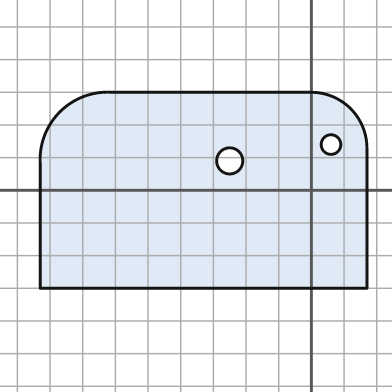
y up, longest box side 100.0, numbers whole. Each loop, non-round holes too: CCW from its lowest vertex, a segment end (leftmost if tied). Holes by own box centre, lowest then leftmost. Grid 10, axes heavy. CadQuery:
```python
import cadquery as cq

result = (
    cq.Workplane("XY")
    .moveTo(-83.0, -30.0)
    .lineTo(17.0, -30.0)
    .lineTo(17.0, 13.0)
    .threePointArc((12.0, 25.0), (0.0, 30.0))
    .lineTo(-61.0, 30.0)
    .threePointArc((-77.0, 24.0), (-83.0, 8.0))
    .close()
    .moveTo(-25.0, 9.0)
    .circle(4.0)
    .moveTo(6.0, 14.0)
    .circle(3.0)
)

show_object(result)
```